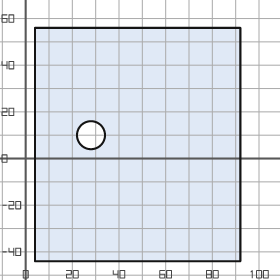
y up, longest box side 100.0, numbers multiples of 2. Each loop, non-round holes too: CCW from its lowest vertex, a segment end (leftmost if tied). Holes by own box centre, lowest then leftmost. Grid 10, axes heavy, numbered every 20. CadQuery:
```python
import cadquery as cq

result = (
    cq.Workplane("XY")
    .moveTo(4.0, -44.0)
    .lineTo(92.0, -44.0)
    .lineTo(92.0, 56.0)
    .lineTo(4.0, 56.0)
    .close()
    .moveTo(28.0, 10.0)
    .circle(6.0)
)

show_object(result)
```